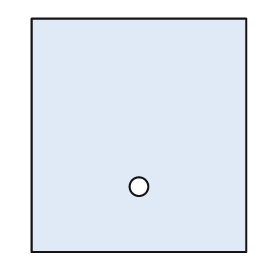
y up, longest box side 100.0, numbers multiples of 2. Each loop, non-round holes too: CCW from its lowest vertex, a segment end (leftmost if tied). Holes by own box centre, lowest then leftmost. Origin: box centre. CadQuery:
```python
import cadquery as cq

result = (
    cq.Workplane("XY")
    .moveTo(-46.0, -50.0)
    .lineTo(46.0, -50.0)
    .lineTo(46.0, 50.0)
    .lineTo(-46.0, 50.0)
    .close()
    .moveTo(0.0, -22.0)
    .circle(4.0)
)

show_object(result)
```